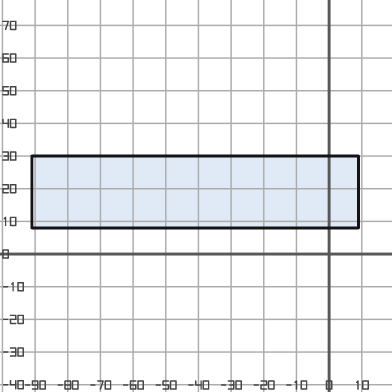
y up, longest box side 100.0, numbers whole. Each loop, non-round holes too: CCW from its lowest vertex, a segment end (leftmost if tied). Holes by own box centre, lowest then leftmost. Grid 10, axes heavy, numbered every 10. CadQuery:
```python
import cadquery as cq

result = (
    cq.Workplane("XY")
    .moveTo(-91.0, 8.0)
    .lineTo(9.0, 8.0)
    .lineTo(9.0, 30.0)
    .lineTo(-91.0, 30.0)
    .close()
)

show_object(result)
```